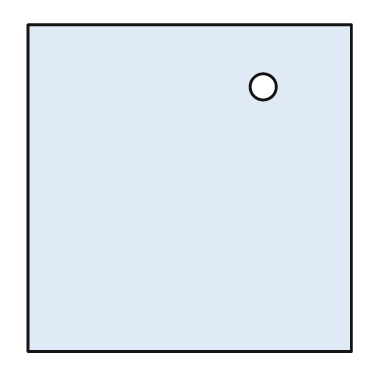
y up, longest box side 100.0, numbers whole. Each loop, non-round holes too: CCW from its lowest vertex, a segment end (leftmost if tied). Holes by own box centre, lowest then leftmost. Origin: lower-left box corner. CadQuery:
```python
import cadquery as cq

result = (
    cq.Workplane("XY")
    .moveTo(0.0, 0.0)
    .lineTo(99.0, 0.0)
    .lineTo(99.0, 100.0)
    .lineTo(0.0, 100.0)
    .close()
    .moveTo(72.0, 81.0)
    .circle(4.0)
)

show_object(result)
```